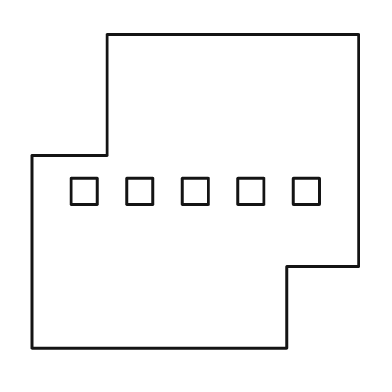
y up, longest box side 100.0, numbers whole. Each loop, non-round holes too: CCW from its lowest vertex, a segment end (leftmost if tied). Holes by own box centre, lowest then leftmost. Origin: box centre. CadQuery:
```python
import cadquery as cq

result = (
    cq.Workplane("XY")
    .moveTo(-50.0, -48.0)
    .lineTo(28.0, -48.0)
    .lineTo(28.0, -23.0)
    .lineTo(50.0, -23.0)
    .lineTo(50.0, 48.0)
    .lineTo(-27.0, 48.0)
    .lineTo(-27.0, 11.0)
    .lineTo(-50.0, 11.0)
    .close()
    .moveTo(-38.0, -4.0)
    .lineTo(-30.0, -4.0)
    .lineTo(-30.0, 4.0)
    .lineTo(-38.0, 4.0)
    .close()
    .moveTo(-21.0, -4.0)
    .lineTo(-13.0, -4.0)
    .lineTo(-13.0, 4.0)
    .lineTo(-21.0, 4.0)
    .close()
    .moveTo(-4.0, -4.0)
    .lineTo(4.0, -4.0)
    .lineTo(4.0, 4.0)
    .lineTo(-4.0, 4.0)
    .close()
    .moveTo(13.0, -4.0)
    .lineTo(21.0, -4.0)
    .lineTo(21.0, 4.0)
    .lineTo(13.0, 4.0)
    .close()
    .moveTo(30.0, -4.0)
    .lineTo(38.0, -4.0)
    .lineTo(38.0, 4.0)
    .lineTo(30.0, 4.0)
    .close()
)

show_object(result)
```